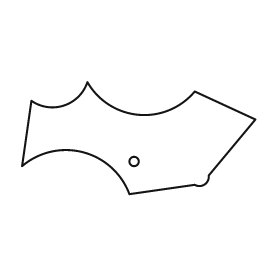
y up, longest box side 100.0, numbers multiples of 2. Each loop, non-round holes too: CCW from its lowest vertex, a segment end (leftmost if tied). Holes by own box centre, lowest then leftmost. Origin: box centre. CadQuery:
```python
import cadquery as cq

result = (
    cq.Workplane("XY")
    .moveTo(-4.0, -24.0)
    .lineTo(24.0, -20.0)
    .threePointArc((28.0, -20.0), (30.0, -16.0))
    .lineTo(50.0, 8.0)
    .lineTo(24.0, 20.0)
    .threePointArc((0.0, 10.0), (-22.0, 24.0))
    .threePointArc((-32.0, 14.0), (-46.0, 16.0))
    .lineTo(-50.0, -12.0)
    .threePointArc((-24.0, -6.0), (-4.0, -24.0))
    .close()
    .moveTo(-2.0, -10.0)
    .circle(2.0)
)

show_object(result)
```